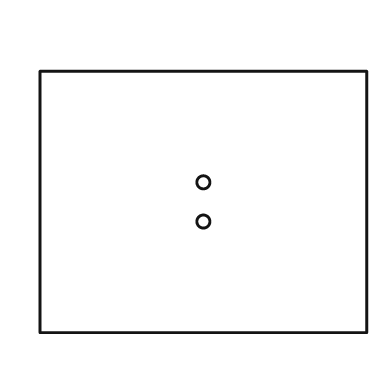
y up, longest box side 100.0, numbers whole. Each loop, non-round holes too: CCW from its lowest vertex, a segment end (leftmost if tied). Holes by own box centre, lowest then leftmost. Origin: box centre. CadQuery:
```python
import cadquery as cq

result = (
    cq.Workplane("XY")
    .moveTo(-50.0, -40.0)
    .lineTo(50.0, -40.0)
    .lineTo(50.0, 40.0)
    .lineTo(-50.0, 40.0)
    .close()
    .moveTo(0.0, -6.0)
    .circle(2.0)
    .moveTo(0.0, 6.0)
    .circle(2.0)
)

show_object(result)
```